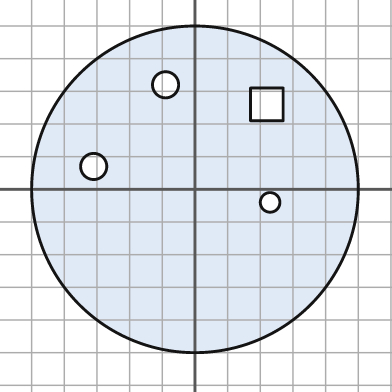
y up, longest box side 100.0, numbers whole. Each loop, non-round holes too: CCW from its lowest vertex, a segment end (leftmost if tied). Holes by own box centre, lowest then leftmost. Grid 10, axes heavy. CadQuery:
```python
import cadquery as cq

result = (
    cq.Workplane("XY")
    .moveTo(0.0, 0.0)
    .circle(50.0)
    .moveTo(23.0, -4.0)
    .circle(3.0)
    .moveTo(-31.0, 7.0)
    .circle(4.0)
    .moveTo(17.0, 21.0)
    .lineTo(27.0, 21.0)
    .lineTo(27.0, 31.0)
    .lineTo(17.0, 31.0)
    .close()
    .moveTo(-9.0, 32.0)
    .circle(4.0)
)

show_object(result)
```